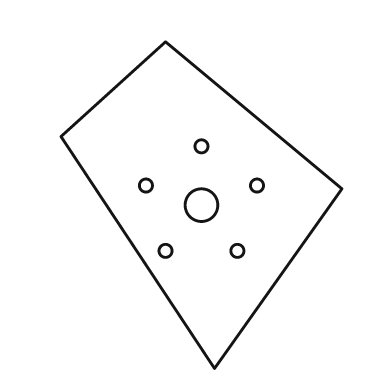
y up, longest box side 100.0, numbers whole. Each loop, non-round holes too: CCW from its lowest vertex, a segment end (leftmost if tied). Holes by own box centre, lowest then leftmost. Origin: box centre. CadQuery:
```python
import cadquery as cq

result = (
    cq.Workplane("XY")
    .moveTo(4.0, -50.0)
    .lineTo(43.0, 5.0)
    .lineTo(-11.0, 50.0)
    .lineTo(-43.0, 21.0)
    .close()
    .moveTo(-11.0, -14.0)
    .circle(2.0)
    .moveTo(11.0, -14.0)
    .circle(2.0)
    .moveTo(0.0, 0.0)
    .circle(5.0)
    .moveTo(-17.0, 6.0)
    .circle(2.0)
    .moveTo(17.0, 6.0)
    .circle(2.0)
    .moveTo(0.0, 18.0)
    .circle(2.0)
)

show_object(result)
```